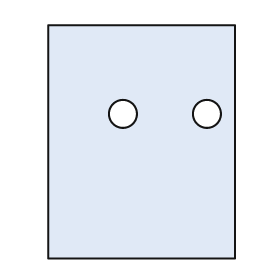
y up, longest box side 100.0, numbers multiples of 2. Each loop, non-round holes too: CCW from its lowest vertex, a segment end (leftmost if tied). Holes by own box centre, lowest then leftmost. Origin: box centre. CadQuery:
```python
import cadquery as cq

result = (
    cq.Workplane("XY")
    .moveTo(-40.0, -50.0)
    .lineTo(40.0, -50.0)
    .lineTo(40.0, 50.0)
    .lineTo(-40.0, 50.0)
    .close()
    .moveTo(-8.0, 12.0)
    .circle(6.0)
    .moveTo(28.0, 12.0)
    .circle(6.0)
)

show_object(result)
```